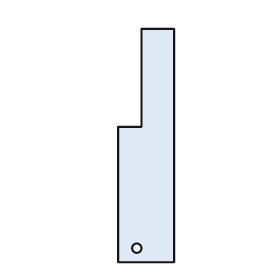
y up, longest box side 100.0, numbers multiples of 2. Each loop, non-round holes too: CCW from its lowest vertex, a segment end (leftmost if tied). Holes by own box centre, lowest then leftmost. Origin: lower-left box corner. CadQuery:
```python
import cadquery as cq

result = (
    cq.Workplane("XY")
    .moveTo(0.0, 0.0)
    .lineTo(24.0, 0.0)
    .lineTo(24.0, 100.0)
    .lineTo(10.0, 100.0)
    .lineTo(10.0, 58.0)
    .lineTo(0.0, 58.0)
    .close()
    .moveTo(8.0, 6.0)
    .circle(2.0)
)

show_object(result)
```